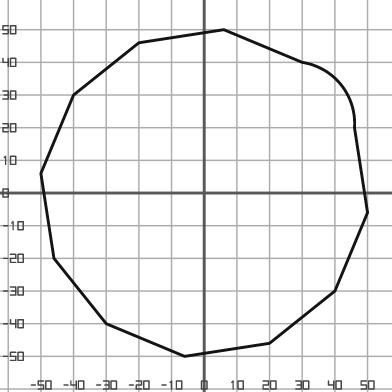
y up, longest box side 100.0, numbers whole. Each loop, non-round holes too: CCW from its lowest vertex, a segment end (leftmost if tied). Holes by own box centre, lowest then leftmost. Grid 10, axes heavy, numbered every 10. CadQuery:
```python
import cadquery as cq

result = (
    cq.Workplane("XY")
    .moveTo(-6.0, -50.0)
    .lineTo(20.0, -46.0)
    .lineTo(40.0, -30.0)
    .lineTo(50.0, -6.0)
    .lineTo(46.0, 20.0)
    .threePointArc((42.0, 33.0), (30.0, 40.0))
    .lineTo(6.0, 50.0)
    .lineTo(-20.0, 46.0)
    .lineTo(-40.0, 30.0)
    .lineTo(-50.0, 6.0)
    .lineTo(-46.0, -20.0)
    .lineTo(-30.0, -40.0)
    .close()
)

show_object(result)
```